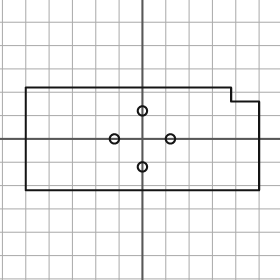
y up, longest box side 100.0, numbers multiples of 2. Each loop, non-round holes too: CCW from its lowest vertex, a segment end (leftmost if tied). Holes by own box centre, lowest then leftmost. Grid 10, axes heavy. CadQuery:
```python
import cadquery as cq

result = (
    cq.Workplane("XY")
    .moveTo(-50.0, -22.0)
    .lineTo(50.0, -22.0)
    .lineTo(50.0, 16.0)
    .lineTo(38.0, 16.0)
    .lineTo(38.0, 22.0)
    .lineTo(-50.0, 22.0)
    .close()
    .moveTo(0.0, -12.0)
    .circle(2.0)
    .moveTo(-12.0, 0.0)
    .circle(2.0)
    .moveTo(12.0, 0.0)
    .circle(2.0)
    .moveTo(0.0, 12.0)
    .circle(2.0)
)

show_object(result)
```